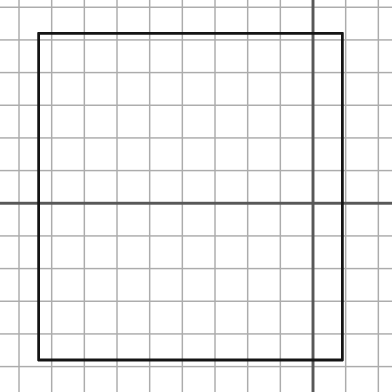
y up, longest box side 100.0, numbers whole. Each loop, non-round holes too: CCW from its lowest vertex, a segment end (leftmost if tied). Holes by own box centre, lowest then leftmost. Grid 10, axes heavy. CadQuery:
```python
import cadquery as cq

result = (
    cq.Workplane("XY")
    .moveTo(-84.0, -48.0)
    .lineTo(9.0, -48.0)
    .lineTo(9.0, 52.0)
    .lineTo(-84.0, 52.0)
    .close()
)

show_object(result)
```